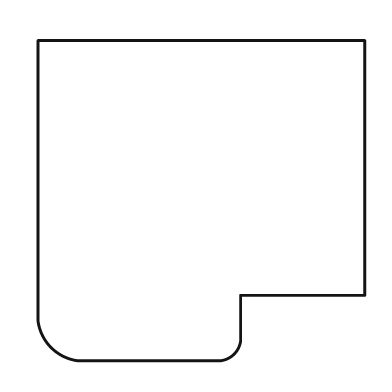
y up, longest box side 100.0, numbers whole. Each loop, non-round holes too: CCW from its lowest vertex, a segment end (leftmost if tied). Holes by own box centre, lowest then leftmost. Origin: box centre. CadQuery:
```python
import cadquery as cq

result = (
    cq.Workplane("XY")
    .moveTo(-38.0, -49.0)
    .lineTo(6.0, -49.0)
    .threePointArc((10.0, -47.0), (12.0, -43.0))
    .lineTo(12.0, -29.0)
    .lineTo(50.0, -29.0)
    .lineTo(50.0, 49.0)
    .lineTo(-50.0, 49.0)
    .lineTo(-50.0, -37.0)
    .threePointArc((-46.0, -45.0), (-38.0, -49.0))
    .close()
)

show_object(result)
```